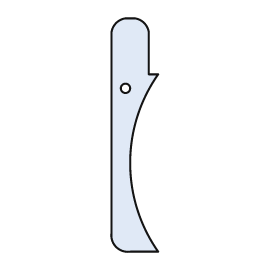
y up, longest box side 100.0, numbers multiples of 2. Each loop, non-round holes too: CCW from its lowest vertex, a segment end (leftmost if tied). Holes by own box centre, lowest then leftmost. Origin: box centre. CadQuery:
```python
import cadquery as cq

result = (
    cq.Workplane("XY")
    .moveTo(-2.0, -50.0)
    .lineTo(10.0, -50.0)
    .threePointArc((-2.0, -12.0), (10.0, 26.0))
    .lineTo(6.0, 26.0)
    .lineTo(6.0, 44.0)
    .threePointArc((4.0, 48.0), (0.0, 50.0))
    .lineTo(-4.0, 50.0)
    .threePointArc((-8.0, 48.0), (-10.0, 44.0))
    .lineTo(-10.0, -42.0)
    .threePointArc((-8.0, -48.0), (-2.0, -50.0))
    .close()
    .moveTo(-4.0, 20.0)
    .circle(2.0)
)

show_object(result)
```